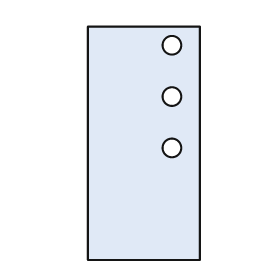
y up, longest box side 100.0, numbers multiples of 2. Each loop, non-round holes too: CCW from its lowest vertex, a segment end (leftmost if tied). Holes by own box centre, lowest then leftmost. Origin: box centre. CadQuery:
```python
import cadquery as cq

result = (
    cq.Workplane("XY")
    .moveTo(-24.0, -50.0)
    .lineTo(24.0, -50.0)
    .lineTo(24.0, 50.0)
    .lineTo(-24.0, 50.0)
    .close()
    .moveTo(12.0, -2.0)
    .circle(4.0)
    .moveTo(12.0, 20.0)
    .circle(4.0)
    .moveTo(12.0, 42.0)
    .circle(4.0)
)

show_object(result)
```